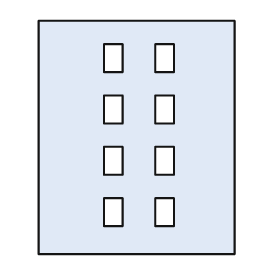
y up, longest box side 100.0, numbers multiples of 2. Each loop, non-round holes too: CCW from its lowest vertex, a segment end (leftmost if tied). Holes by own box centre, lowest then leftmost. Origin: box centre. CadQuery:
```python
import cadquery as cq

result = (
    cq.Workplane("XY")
    .moveTo(-42.0, -50.0)
    .lineTo(42.0, -50.0)
    .lineTo(42.0, 50.0)
    .lineTo(-42.0, 50.0)
    .close()
    .moveTo(-14.0, -38.0)
    .lineTo(-6.0, -38.0)
    .lineTo(-6.0, -26.0)
    .lineTo(-14.0, -26.0)
    .close()
    .moveTo(8.0, -38.0)
    .lineTo(16.0, -38.0)
    .lineTo(16.0, -26.0)
    .lineTo(8.0, -26.0)
    .close()
    .moveTo(-14.0, -16.0)
    .lineTo(-6.0, -16.0)
    .lineTo(-6.0, -4.0)
    .lineTo(-14.0, -4.0)
    .close()
    .moveTo(8.0, -16.0)
    .lineTo(16.0, -16.0)
    .lineTo(16.0, -4.0)
    .lineTo(8.0, -4.0)
    .close()
    .moveTo(-14.0, 6.0)
    .lineTo(-6.0, 6.0)
    .lineTo(-6.0, 18.0)
    .lineTo(-14.0, 18.0)
    .close()
    .moveTo(8.0, 6.0)
    .lineTo(16.0, 6.0)
    .lineTo(16.0, 18.0)
    .lineTo(8.0, 18.0)
    .close()
    .moveTo(-14.0, 28.0)
    .lineTo(-6.0, 28.0)
    .lineTo(-6.0, 40.0)
    .lineTo(-14.0, 40.0)
    .close()
    .moveTo(8.0, 28.0)
    .lineTo(16.0, 28.0)
    .lineTo(16.0, 40.0)
    .lineTo(8.0, 40.0)
    .close()
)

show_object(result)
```